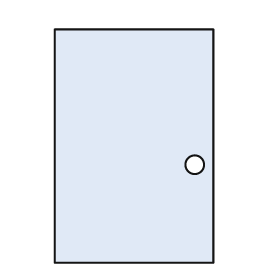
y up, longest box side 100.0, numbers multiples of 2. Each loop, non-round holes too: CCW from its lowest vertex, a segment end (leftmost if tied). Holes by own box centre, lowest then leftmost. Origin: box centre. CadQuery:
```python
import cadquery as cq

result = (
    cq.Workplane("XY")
    .moveTo(-34.0, -50.0)
    .lineTo(34.0, -50.0)
    .lineTo(34.0, 50.0)
    .lineTo(-34.0, 50.0)
    .close()
    .moveTo(26.0, -8.0)
    .circle(4.0)
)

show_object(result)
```